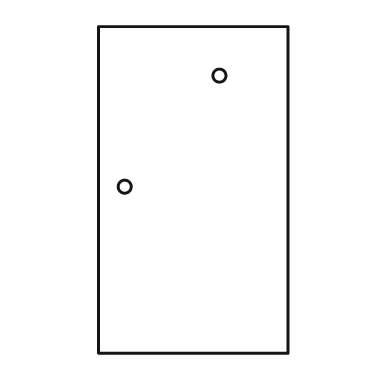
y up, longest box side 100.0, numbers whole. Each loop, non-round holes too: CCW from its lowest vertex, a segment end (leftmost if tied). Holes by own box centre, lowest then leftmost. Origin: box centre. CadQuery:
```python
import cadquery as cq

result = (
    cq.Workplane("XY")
    .moveTo(-29.0, -50.0)
    .lineTo(29.0, -50.0)
    .lineTo(29.0, 50.0)
    .lineTo(-29.0, 50.0)
    .close()
    .moveTo(-21.0, 1.0)
    .circle(2.0)
    .moveTo(8.0, 35.0)
    .circle(2.0)
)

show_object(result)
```